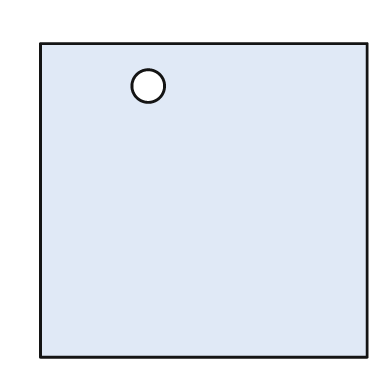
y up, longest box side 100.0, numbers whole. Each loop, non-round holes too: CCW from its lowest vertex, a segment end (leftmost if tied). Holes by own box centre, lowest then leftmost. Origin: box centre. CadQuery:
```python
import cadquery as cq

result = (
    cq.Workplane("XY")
    .moveTo(-50.0, -48.0)
    .lineTo(50.0, -48.0)
    .lineTo(50.0, 48.0)
    .lineTo(-50.0, 48.0)
    .close()
    .moveTo(-17.0, 35.0)
    .circle(5.0)
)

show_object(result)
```